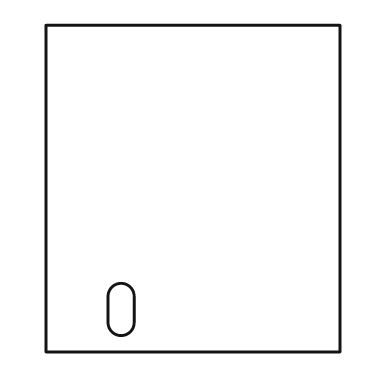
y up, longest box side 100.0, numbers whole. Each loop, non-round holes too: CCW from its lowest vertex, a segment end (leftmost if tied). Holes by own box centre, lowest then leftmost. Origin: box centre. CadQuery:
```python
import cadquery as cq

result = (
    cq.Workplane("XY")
    .moveTo(-45.0, -50.0)
    .lineTo(45.0, -50.0)
    .lineTo(45.0, 50.0)
    .lineTo(-45.0, 50.0)
    .close()
    .moveTo(-26.0, -41.0)
    .threePointArc((-22.0, -45.0), (-18.0, -41.0))
    .lineTo(-18.0, -33.0)
    .threePointArc((-22.0, -29.0), (-26.0, -33.0))
    .close()
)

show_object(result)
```